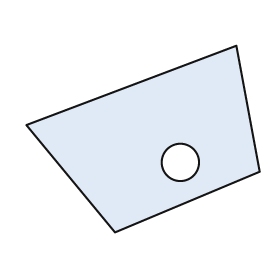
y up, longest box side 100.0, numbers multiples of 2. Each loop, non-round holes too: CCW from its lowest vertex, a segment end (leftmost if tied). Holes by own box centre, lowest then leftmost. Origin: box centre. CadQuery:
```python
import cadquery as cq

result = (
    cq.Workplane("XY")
    .moveTo(-12.0, -40.0)
    .lineTo(50.0, -14.0)
    .lineTo(40.0, 40.0)
    .lineTo(-50.0, 6.0)
    .close()
    .moveTo(16.0, -10.0)
    .circle(8.0)
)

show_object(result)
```